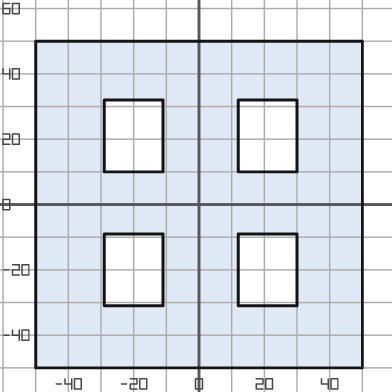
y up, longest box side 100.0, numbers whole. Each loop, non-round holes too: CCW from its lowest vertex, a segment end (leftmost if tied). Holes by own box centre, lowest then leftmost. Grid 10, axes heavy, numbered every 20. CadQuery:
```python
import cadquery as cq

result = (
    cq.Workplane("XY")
    .moveTo(-50.0, -50.0)
    .lineTo(50.0, -50.0)
    .lineTo(50.0, 50.0)
    .lineTo(-50.0, 50.0)
    .close()
    .moveTo(-29.0, -31.0)
    .lineTo(-11.0, -31.0)
    .lineTo(-11.0, -9.0)
    .lineTo(-29.0, -9.0)
    .close()
    .moveTo(12.0, -31.0)
    .lineTo(30.0, -31.0)
    .lineTo(30.0, -9.0)
    .lineTo(12.0, -9.0)
    .close()
    .moveTo(-29.0, 10.0)
    .lineTo(-11.0, 10.0)
    .lineTo(-11.0, 32.0)
    .lineTo(-29.0, 32.0)
    .close()
    .moveTo(12.0, 10.0)
    .lineTo(30.0, 10.0)
    .lineTo(30.0, 32.0)
    .lineTo(12.0, 32.0)
    .close()
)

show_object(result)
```